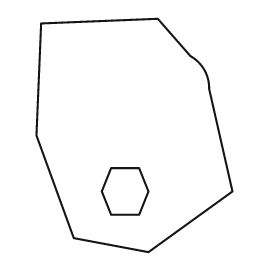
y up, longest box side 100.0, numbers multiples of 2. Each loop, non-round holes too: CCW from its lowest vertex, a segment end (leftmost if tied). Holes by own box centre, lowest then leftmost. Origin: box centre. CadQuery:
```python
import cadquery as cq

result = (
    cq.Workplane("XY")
    .moveTo(6.0, -50.0)
    .lineTo(42.0, -24.0)
    .lineTo(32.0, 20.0)
    .threePointArc((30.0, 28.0), (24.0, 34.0))
    .lineTo(10.0, 50.0)
    .lineTo(-40.0, 48.0)
    .lineTo(-42.0, 0.0)
    .lineTo(-26.0, -44.0)
    .close()
    .moveTo(-10.0, -34.0)
    .lineTo(2.0, -34.0)
    .lineTo(6.0, -24.0)
    .lineTo(2.0, -14.0)
    .lineTo(-10.0, -14.0)
    .lineTo(-14.0, -24.0)
    .close()
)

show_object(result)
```